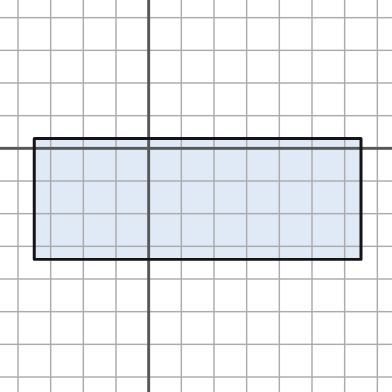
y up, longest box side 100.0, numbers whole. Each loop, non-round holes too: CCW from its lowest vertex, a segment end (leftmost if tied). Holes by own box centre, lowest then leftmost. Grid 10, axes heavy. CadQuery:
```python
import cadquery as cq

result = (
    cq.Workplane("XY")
    .moveTo(-35.0, -34.0)
    .lineTo(65.0, -34.0)
    .lineTo(65.0, 3.0)
    .lineTo(-35.0, 3.0)
    .close()
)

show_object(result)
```